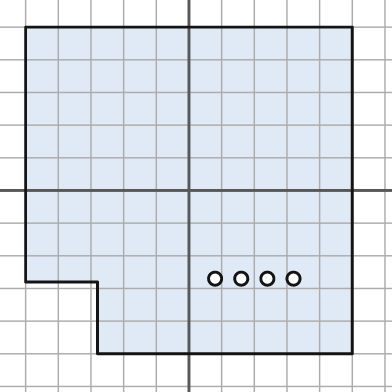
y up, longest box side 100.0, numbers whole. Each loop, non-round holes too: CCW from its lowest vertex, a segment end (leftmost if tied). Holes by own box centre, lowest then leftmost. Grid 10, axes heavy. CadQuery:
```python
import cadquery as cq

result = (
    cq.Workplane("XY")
    .moveTo(-28.0, -50.0)
    .lineTo(50.0, -50.0)
    .lineTo(50.0, 50.0)
    .lineTo(-50.0, 50.0)
    .lineTo(-50.0, -28.0)
    .lineTo(-28.0, -28.0)
    .close()
    .moveTo(8.0, -27.0)
    .circle(2.0)
    .moveTo(16.0, -27.0)
    .circle(2.0)
    .moveTo(24.0, -27.0)
    .circle(2.0)
    .moveTo(32.0, -27.0)
    .circle(2.0)
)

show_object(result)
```